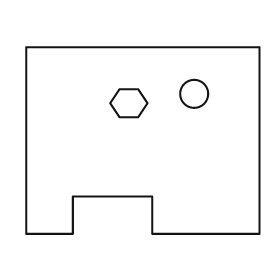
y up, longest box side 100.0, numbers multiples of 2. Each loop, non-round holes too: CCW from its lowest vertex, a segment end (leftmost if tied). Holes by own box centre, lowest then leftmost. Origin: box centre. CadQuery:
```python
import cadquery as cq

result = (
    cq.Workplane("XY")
    .moveTo(-50.0, -40.0)
    .lineTo(-30.0, -40.0)
    .lineTo(-30.0, -24.0)
    .lineTo(4.0, -24.0)
    .lineTo(4.0, -40.0)
    .lineTo(50.0, -40.0)
    .lineTo(50.0, 40.0)
    .lineTo(-50.0, 40.0)
    .close()
    .moveTo(-10.0, 10.0)
    .lineTo(-2.0, 10.0)
    .lineTo(2.0, 16.0)
    .lineTo(-2.0, 22.0)
    .lineTo(-10.0, 22.0)
    .lineTo(-14.0, 16.0)
    .close()
    .moveTo(22.0, 20.0)
    .circle(6.0)
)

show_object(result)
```